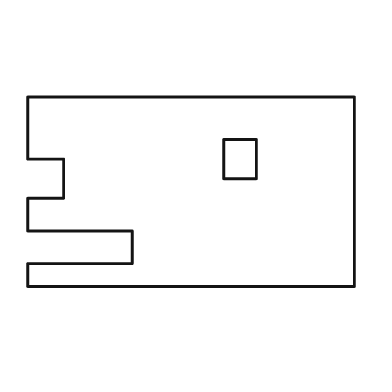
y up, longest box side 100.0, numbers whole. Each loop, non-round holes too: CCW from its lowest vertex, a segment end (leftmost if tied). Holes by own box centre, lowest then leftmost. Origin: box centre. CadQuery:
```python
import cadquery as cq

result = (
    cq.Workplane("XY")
    .moveTo(-50.0, -29.0)
    .lineTo(50.0, -29.0)
    .lineTo(50.0, 29.0)
    .lineTo(-50.0, 29.0)
    .lineTo(-50.0, 10.0)
    .lineTo(-39.0, 10.0)
    .lineTo(-39.0, -2.0)
    .lineTo(-50.0, -2.0)
    .lineTo(-50.0, -12.0)
    .lineTo(-18.0, -12.0)
    .lineTo(-18.0, -22.0)
    .lineTo(-50.0, -22.0)
    .close()
    .moveTo(10.0, 4.0)
    .lineTo(20.0, 4.0)
    .lineTo(20.0, 16.0)
    .lineTo(10.0, 16.0)
    .close()
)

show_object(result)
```